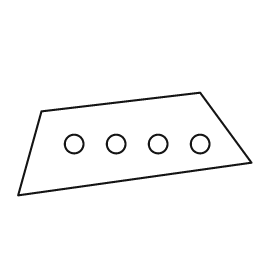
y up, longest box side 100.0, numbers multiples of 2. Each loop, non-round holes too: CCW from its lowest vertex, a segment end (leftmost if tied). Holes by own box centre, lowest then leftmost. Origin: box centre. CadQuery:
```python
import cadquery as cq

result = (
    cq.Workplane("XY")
    .moveTo(-50.0, -22.0)
    .lineTo(50.0, -8.0)
    .lineTo(28.0, 22.0)
    .lineTo(-40.0, 14.0)
    .close()
    .moveTo(-26.0, 0.0)
    .circle(4.0)
    .moveTo(-8.0, 0.0)
    .circle(4.0)
    .moveTo(10.0, 0.0)
    .circle(4.0)
    .moveTo(28.0, 0.0)
    .circle(4.0)
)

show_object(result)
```